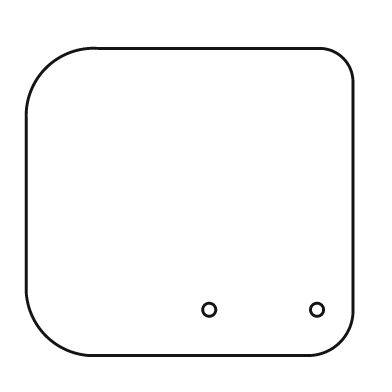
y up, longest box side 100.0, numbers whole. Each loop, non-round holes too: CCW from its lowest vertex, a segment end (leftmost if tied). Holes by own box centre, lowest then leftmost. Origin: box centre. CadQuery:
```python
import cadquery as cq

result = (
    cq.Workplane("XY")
    .moveTo(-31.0, -47.0)
    .lineTo(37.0, -47.0)
    .threePointArc((46.0, -43.0), (50.0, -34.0))
    .lineTo(50.0, 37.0)
    .threePointArc((47.0, 44.0), (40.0, 47.0))
    .lineTo(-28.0, 47.0)
    .threePointArc((-44.0, 41.0), (-50.0, 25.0))
    .lineTo(-50.0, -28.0)
    .threePointArc((-44.0, -41.0), (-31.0, -47.0))
    .close()
    .moveTo(6.0, -33.0)
    .circle(2.0)
    .moveTo(39.0, -33.0)
    .circle(2.0)
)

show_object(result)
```